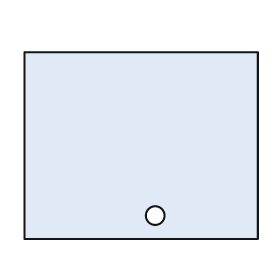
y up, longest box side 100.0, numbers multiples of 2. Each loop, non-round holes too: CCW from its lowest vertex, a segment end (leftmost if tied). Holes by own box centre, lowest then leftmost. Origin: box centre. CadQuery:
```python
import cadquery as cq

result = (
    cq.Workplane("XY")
    .moveTo(-50.0, -40.0)
    .lineTo(50.0, -40.0)
    .lineTo(50.0, 40.0)
    .lineTo(-50.0, 40.0)
    .close()
    .moveTo(6.0, -30.0)
    .circle(4.0)
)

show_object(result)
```